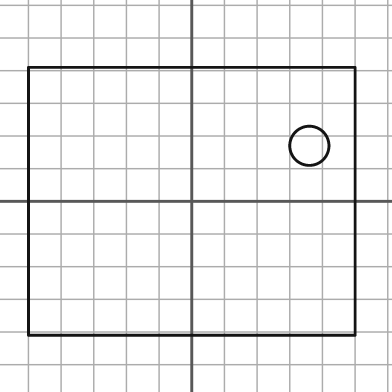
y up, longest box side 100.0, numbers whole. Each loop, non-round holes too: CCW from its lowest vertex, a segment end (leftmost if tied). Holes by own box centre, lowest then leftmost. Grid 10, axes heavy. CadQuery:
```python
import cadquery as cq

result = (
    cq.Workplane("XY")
    .moveTo(-50.0, -41.0)
    .lineTo(50.0, -41.0)
    .lineTo(50.0, 41.0)
    .lineTo(-50.0, 41.0)
    .close()
    .moveTo(36.0, 17.0)
    .circle(6.0)
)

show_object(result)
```